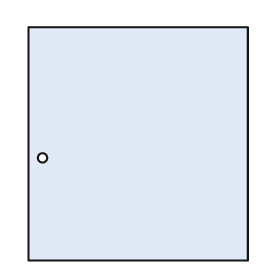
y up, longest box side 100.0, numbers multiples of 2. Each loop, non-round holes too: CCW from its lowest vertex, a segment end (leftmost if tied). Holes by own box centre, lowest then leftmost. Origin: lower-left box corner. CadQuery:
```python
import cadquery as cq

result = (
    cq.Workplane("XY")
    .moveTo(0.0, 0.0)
    .lineTo(94.0, 0.0)
    .lineTo(94.0, 100.0)
    .lineTo(0.0, 100.0)
    .close()
    .moveTo(6.0, 44.0)
    .circle(2.0)
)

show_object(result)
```